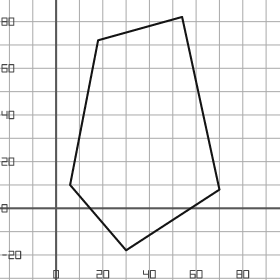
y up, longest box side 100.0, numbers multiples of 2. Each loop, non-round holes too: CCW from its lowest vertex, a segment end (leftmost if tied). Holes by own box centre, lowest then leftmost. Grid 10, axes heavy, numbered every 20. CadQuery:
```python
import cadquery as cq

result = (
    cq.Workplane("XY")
    .moveTo(30.0, -18.0)
    .lineTo(70.0, 8.0)
    .lineTo(54.0, 82.0)
    .lineTo(18.0, 72.0)
    .lineTo(6.0, 10.0)
    .close()
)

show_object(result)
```